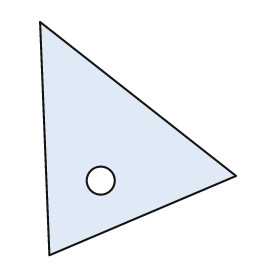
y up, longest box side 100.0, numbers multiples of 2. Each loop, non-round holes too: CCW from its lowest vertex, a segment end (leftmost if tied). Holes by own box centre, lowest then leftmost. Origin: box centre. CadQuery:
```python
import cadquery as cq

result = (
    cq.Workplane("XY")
    .moveTo(-38.0, -50.0)
    .lineTo(42.0, -16.0)
    .lineTo(-42.0, 50.0)
    .close()
    .moveTo(-16.0, -18.0)
    .circle(6.0)
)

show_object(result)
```